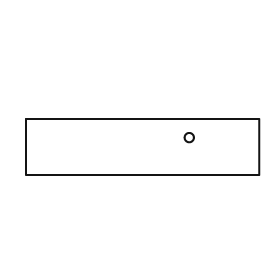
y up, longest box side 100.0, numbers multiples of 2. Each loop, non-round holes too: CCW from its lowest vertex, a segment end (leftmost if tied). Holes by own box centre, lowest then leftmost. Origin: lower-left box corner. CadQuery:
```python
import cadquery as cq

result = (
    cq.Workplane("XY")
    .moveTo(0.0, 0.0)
    .lineTo(100.0, 0.0)
    .lineTo(100.0, 24.0)
    .lineTo(0.0, 24.0)
    .close()
    .moveTo(70.0, 16.0)
    .circle(2.0)
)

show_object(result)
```